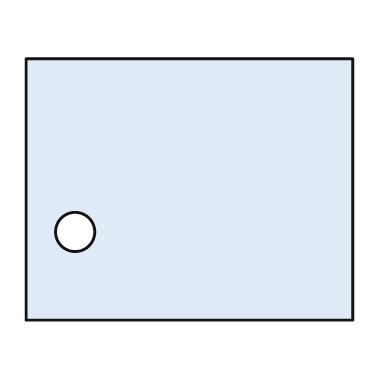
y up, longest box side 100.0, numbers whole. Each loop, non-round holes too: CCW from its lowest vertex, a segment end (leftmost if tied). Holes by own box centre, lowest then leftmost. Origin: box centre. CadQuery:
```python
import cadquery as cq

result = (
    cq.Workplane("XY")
    .moveTo(-50.0, -40.0)
    .lineTo(50.0, -40.0)
    .lineTo(50.0, 40.0)
    .lineTo(-50.0, 40.0)
    .close()
    .moveTo(-35.0, -13.0)
    .circle(6.0)
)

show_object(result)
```